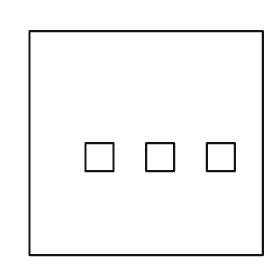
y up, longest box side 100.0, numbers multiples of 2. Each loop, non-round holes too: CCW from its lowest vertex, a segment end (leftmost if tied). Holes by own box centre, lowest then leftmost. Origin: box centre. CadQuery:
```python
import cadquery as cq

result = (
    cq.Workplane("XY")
    .moveTo(-50.0, -48.0)
    .lineTo(50.0, -48.0)
    .lineTo(50.0, 48.0)
    .lineTo(-50.0, 48.0)
    .close()
    .moveTo(-26.0, -12.0)
    .lineTo(-14.0, -12.0)
    .lineTo(-14.0, 0.0)
    .lineTo(-26.0, 0.0)
    .close()
    .moveTo(0.0, -12.0)
    .lineTo(12.0, -12.0)
    .lineTo(12.0, 0.0)
    .lineTo(0.0, 0.0)
    .close()
    .moveTo(26.0, -12.0)
    .lineTo(38.0, -12.0)
    .lineTo(38.0, 0.0)
    .lineTo(26.0, 0.0)
    .close()
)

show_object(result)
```